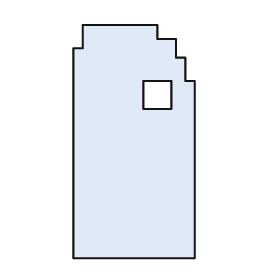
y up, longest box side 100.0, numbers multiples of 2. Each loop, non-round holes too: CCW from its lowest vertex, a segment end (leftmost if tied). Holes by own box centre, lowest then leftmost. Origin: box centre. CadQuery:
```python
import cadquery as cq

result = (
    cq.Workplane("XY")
    .moveTo(-26.0, -50.0)
    .lineTo(26.0, -50.0)
    .lineTo(26.0, 26.0)
    .lineTo(22.0, 26.0)
    .lineTo(22.0, 36.0)
    .lineTo(18.0, 36.0)
    .lineTo(18.0, 44.0)
    .lineTo(10.0, 44.0)
    .lineTo(10.0, 50.0)
    .lineTo(-22.0, 50.0)
    .lineTo(-22.0, 40.0)
    .lineTo(-26.0, 40.0)
    .close()
    .moveTo(4.0, 14.0)
    .lineTo(16.0, 14.0)
    .lineTo(16.0, 26.0)
    .lineTo(4.0, 26.0)
    .close()
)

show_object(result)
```